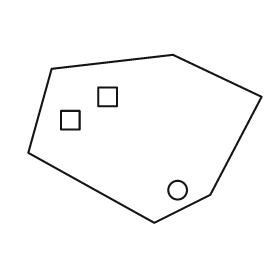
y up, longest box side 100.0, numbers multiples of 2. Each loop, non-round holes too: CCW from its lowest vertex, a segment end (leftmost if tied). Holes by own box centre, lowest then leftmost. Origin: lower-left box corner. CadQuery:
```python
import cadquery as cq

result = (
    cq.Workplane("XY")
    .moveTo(54.0, 0.0)
    .lineTo(78.0, 12.0)
    .lineTo(100.0, 54.0)
    .lineTo(62.0, 72.0)
    .lineTo(10.0, 66.0)
    .lineTo(0.0, 30.0)
    .close()
    .moveTo(64.0, 14.0)
    .circle(4.0)
    .moveTo(14.0, 40.0)
    .lineTo(22.0, 40.0)
    .lineTo(22.0, 48.0)
    .lineTo(14.0, 48.0)
    .close()
    .moveTo(30.0, 50.0)
    .lineTo(38.0, 50.0)
    .lineTo(38.0, 58.0)
    .lineTo(30.0, 58.0)
    .close()
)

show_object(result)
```